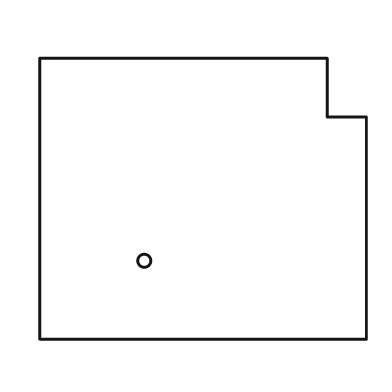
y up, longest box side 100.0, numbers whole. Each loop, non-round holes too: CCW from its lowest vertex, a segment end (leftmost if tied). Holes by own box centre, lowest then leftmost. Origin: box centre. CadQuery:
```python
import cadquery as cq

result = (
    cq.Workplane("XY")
    .moveTo(-50.0, -43.0)
    .lineTo(50.0, -43.0)
    .lineTo(50.0, 25.0)
    .lineTo(38.0, 25.0)
    .lineTo(38.0, 43.0)
    .lineTo(-50.0, 43.0)
    .close()
    .moveTo(-18.0, -19.0)
    .circle(2.0)
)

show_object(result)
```